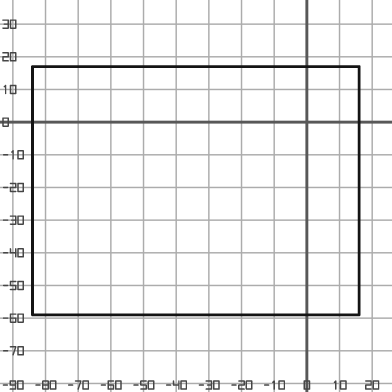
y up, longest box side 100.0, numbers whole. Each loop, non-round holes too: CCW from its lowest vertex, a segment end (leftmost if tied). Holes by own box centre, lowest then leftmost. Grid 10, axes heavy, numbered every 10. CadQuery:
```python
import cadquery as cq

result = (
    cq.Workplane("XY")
    .moveTo(-84.0, -59.0)
    .lineTo(16.0, -59.0)
    .lineTo(16.0, 17.0)
    .lineTo(-84.0, 17.0)
    .close()
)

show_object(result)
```